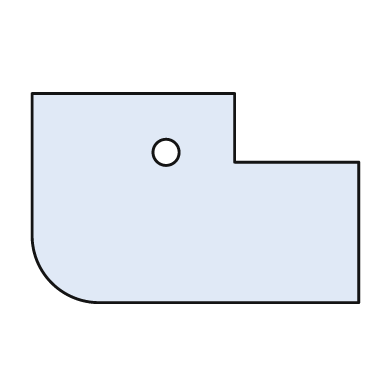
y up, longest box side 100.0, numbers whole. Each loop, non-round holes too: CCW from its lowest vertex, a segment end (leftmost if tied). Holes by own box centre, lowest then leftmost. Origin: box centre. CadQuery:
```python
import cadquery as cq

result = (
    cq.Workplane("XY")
    .moveTo(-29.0, -32.0)
    .lineTo(50.0, -32.0)
    .lineTo(50.0, 11.0)
    .lineTo(12.0, 11.0)
    .lineTo(12.0, 32.0)
    .lineTo(-50.0, 32.0)
    .lineTo(-50.0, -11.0)
    .threePointArc((-44.0, -26.0), (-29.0, -32.0))
    .close()
    .moveTo(-9.0, 14.0)
    .circle(4.0)
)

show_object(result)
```